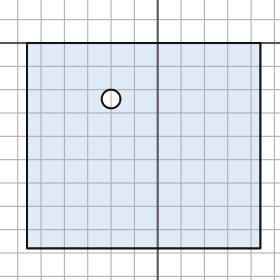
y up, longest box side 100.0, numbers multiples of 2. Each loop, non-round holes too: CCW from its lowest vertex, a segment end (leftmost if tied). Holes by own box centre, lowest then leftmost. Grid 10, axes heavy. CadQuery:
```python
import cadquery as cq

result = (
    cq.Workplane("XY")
    .moveTo(-56.0, -88.0)
    .lineTo(44.0, -88.0)
    .lineTo(44.0, 0.0)
    .lineTo(-56.0, 0.0)
    .close()
    .moveTo(-20.0, -24.0)
    .circle(4.0)
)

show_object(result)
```